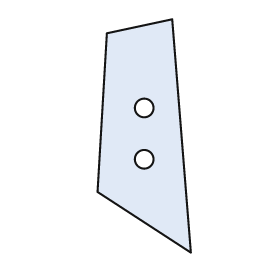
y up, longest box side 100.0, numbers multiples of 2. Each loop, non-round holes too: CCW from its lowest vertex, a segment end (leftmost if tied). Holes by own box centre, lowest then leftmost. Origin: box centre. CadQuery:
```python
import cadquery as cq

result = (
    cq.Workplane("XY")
    .moveTo(20.0, -50.0)
    .lineTo(12.0, 50.0)
    .lineTo(-16.0, 44.0)
    .lineTo(-20.0, -24.0)
    .close()
    .moveTo(0.0, -10.0)
    .circle(4.0)
    .moveTo(0.0, 12.0)
    .circle(4.0)
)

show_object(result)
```